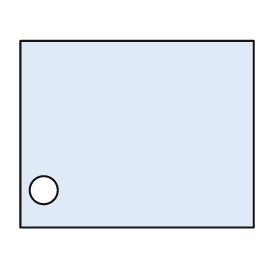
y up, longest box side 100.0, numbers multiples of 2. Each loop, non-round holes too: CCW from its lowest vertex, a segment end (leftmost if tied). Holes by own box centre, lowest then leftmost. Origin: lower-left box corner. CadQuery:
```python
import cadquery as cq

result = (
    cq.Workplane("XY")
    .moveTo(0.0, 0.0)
    .lineTo(100.0, 0.0)
    .lineTo(100.0, 80.0)
    .lineTo(0.0, 80.0)
    .close()
    .moveTo(10.0, 16.0)
    .circle(6.0)
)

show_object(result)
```